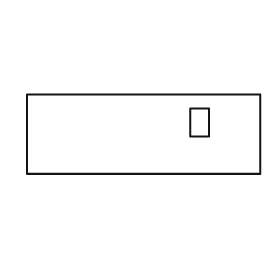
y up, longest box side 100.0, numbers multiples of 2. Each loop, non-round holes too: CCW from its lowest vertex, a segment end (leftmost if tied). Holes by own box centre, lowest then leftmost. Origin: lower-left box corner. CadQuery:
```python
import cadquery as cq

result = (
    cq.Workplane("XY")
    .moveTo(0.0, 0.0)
    .lineTo(100.0, 0.0)
    .lineTo(100.0, 34.0)
    .lineTo(0.0, 34.0)
    .close()
    .moveTo(70.0, 16.0)
    .lineTo(78.0, 16.0)
    .lineTo(78.0, 28.0)
    .lineTo(70.0, 28.0)
    .close()
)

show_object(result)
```